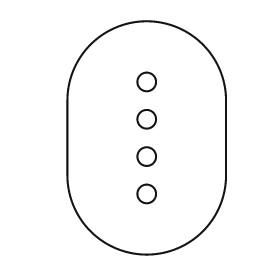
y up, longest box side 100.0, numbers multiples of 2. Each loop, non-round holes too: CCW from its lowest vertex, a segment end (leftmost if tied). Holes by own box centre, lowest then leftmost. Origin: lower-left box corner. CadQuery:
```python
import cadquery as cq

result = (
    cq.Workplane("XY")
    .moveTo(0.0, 34.0)
    .threePointArc((34.0, 0.0), (68.0, 34.0))
    .lineTo(68.0, 66.0)
    .threePointArc((34.0, 100.0), (0.0, 66.0))
    .close()
    .moveTo(34.0, 26.0)
    .circle(4.0)
    .moveTo(34.0, 42.0)
    .circle(4.0)
    .moveTo(34.0, 58.0)
    .circle(4.0)
    .moveTo(34.0, 74.0)
    .circle(4.0)
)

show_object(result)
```